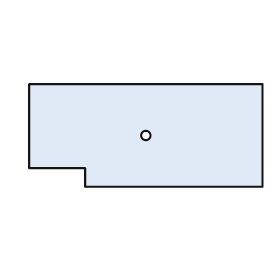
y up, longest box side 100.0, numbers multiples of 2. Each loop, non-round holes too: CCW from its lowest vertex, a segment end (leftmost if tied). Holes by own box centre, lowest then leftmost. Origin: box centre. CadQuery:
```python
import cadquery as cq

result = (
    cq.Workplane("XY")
    .moveTo(-26.0, -22.0)
    .lineTo(50.0, -22.0)
    .lineTo(50.0, 22.0)
    .lineTo(-50.0, 22.0)
    .lineTo(-50.0, -14.0)
    .lineTo(-26.0, -14.0)
    .close()
    .moveTo(0.0, 0.0)
    .circle(2.0)
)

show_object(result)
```